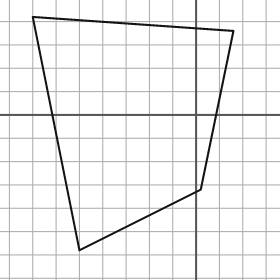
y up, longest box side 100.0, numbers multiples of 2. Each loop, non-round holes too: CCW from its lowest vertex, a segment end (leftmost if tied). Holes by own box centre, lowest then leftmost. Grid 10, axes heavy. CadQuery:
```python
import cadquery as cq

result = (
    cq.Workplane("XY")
    .moveTo(-50.0, -58.0)
    .lineTo(2.0, -32.0)
    .lineTo(16.0, 36.0)
    .lineTo(-70.0, 42.0)
    .close()
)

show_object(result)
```